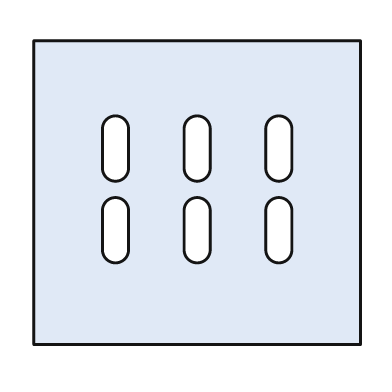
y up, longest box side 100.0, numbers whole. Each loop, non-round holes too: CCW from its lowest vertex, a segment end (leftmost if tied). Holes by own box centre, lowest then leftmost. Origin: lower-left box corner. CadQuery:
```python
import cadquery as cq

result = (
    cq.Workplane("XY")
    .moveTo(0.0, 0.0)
    .lineTo(100.0, 0.0)
    .lineTo(100.0, 93.0)
    .lineTo(0.0, 93.0)
    .close()
    .moveTo(21.0, 29.0)
    .threePointArc((25.0, 25.0), (29.0, 29.0))
    .lineTo(29.0, 41.0)
    .threePointArc((25.0, 45.0), (21.0, 41.0))
    .close()
    .moveTo(46.0, 29.0)
    .threePointArc((50.0, 25.0), (54.0, 29.0))
    .lineTo(54.0, 41.0)
    .threePointArc((50.0, 45.0), (46.0, 41.0))
    .close()
    .moveTo(71.0, 29.0)
    .threePointArc((75.0, 25.0), (79.0, 29.0))
    .lineTo(79.0, 41.0)
    .threePointArc((75.0, 45.0), (71.0, 41.0))
    .close()
    .moveTo(21.0, 54.0)
    .threePointArc((25.0, 50.0), (29.0, 54.0))
    .lineTo(29.0, 66.0)
    .threePointArc((25.0, 70.0), (21.0, 66.0))
    .close()
    .moveTo(46.0, 54.0)
    .threePointArc((50.0, 50.0), (54.0, 54.0))
    .lineTo(54.0, 66.0)
    .threePointArc((50.0, 70.0), (46.0, 66.0))
    .close()
    .moveTo(71.0, 54.0)
    .threePointArc((75.0, 50.0), (79.0, 54.0))
    .lineTo(79.0, 66.0)
    .threePointArc((75.0, 70.0), (71.0, 66.0))
    .close()
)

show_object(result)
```